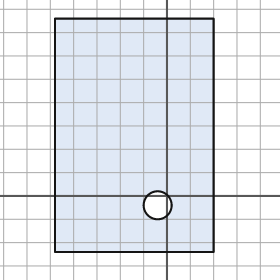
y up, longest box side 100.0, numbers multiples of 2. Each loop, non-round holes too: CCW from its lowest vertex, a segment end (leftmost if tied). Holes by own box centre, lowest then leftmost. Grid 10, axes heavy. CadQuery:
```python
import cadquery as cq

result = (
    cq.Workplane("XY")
    .moveTo(-48.0, -24.0)
    .lineTo(20.0, -24.0)
    .lineTo(20.0, 76.0)
    .lineTo(-48.0, 76.0)
    .close()
    .moveTo(-4.0, -4.0)
    .circle(6.0)
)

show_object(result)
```